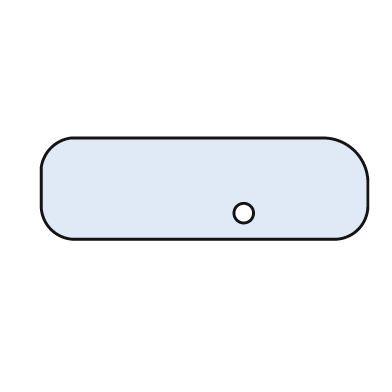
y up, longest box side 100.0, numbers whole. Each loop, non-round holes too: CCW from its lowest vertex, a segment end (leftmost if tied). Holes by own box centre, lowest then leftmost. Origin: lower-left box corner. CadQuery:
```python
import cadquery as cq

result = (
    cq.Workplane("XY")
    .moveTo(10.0, 0.0)
    .lineTo(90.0, 0.0)
    .threePointArc((97.0, 3.0), (100.0, 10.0))
    .lineTo(100.0, 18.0)
    .threePointArc((96.0, 27.0), (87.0, 31.0))
    .lineTo(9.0, 31.0)
    .threePointArc((3.0, 28.0), (0.0, 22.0))
    .lineTo(0.0, 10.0)
    .threePointArc((3.0, 3.0), (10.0, 0.0))
    .close()
    .moveTo(62.0, 8.0)
    .circle(3.0)
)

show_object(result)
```